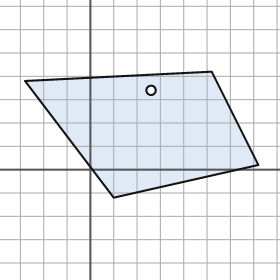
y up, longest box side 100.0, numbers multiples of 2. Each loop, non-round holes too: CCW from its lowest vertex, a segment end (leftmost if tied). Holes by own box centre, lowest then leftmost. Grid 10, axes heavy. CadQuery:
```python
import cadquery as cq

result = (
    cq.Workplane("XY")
    .moveTo(10.0, -12.0)
    .lineTo(72.0, 2.0)
    .lineTo(52.0, 42.0)
    .lineTo(-28.0, 38.0)
    .close()
    .moveTo(26.0, 34.0)
    .circle(2.0)
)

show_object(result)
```